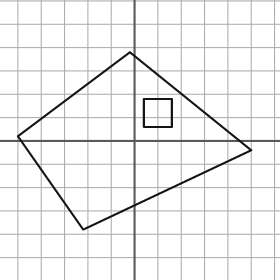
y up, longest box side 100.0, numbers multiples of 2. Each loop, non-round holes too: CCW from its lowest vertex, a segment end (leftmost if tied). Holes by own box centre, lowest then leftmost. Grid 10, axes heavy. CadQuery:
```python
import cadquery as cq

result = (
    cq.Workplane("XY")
    .moveTo(-22.0, -38.0)
    .lineTo(50.0, -4.0)
    .lineTo(-2.0, 38.0)
    .lineTo(-50.0, 2.0)
    .close()
    .moveTo(4.0, 6.0)
    .lineTo(16.0, 6.0)
    .lineTo(16.0, 18.0)
    .lineTo(4.0, 18.0)
    .close()
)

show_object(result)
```